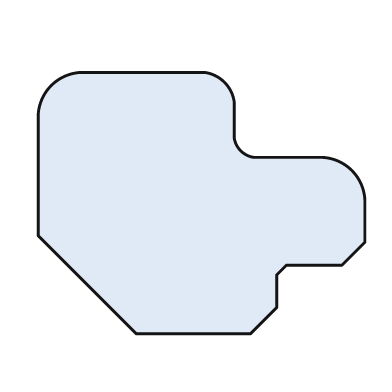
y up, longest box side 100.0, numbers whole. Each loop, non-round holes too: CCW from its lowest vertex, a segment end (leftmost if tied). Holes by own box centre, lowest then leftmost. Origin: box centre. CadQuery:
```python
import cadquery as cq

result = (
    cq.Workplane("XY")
    .moveTo(-20.0, -40.0)
    .lineTo(15.0, -40.0)
    .lineTo(23.0, -32.0)
    .lineTo(23.0, -22.0)
    .lineTo(26.0, -19.0)
    .lineTo(43.0, -19.0)
    .lineTo(50.0, -12.0)
    .lineTo(50.0, 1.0)
    .threePointArc((46.0, 10.0), (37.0, 14.0))
    .lineTo(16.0, 14.0)
    .threePointArc((12.0, 16.0), (10.0, 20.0))
    .lineTo(10.0, 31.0)
    .threePointArc((7.0, 37.0), (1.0, 40.0))
    .lineTo(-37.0, 40.0)
    .threePointArc((-46.0, 36.0), (-50.0, 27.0))
    .lineTo(-50.0, -10.0)
    .close()
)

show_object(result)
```